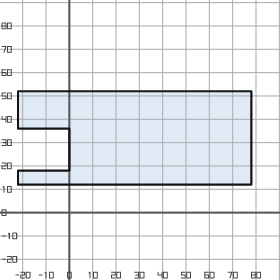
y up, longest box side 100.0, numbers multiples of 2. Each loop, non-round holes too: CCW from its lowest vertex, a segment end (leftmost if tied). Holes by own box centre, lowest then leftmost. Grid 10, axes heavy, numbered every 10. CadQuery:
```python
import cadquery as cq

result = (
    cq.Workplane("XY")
    .moveTo(-22.0, 12.0)
    .lineTo(78.0, 12.0)
    .lineTo(78.0, 52.0)
    .lineTo(-22.0, 52.0)
    .lineTo(-22.0, 36.0)
    .lineTo(0.0, 36.0)
    .lineTo(0.0, 18.0)
    .lineTo(-22.0, 18.0)
    .close()
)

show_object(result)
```